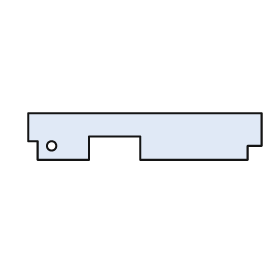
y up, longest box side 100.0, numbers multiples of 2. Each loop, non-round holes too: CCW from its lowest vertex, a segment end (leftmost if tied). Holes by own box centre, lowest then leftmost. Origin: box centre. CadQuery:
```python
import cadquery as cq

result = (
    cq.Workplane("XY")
    .moveTo(-46.0, -10.0)
    .lineTo(-24.0, -10.0)
    .lineTo(-24.0, 0.0)
    .lineTo(-2.0, 0.0)
    .lineTo(-2.0, -10.0)
    .lineTo(44.0, -10.0)
    .lineTo(44.0, -4.0)
    .lineTo(50.0, -4.0)
    .lineTo(50.0, 10.0)
    .lineTo(-50.0, 10.0)
    .lineTo(-50.0, -2.0)
    .lineTo(-46.0, -2.0)
    .close()
    .moveTo(-40.0, -4.0)
    .circle(2.0)
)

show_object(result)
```